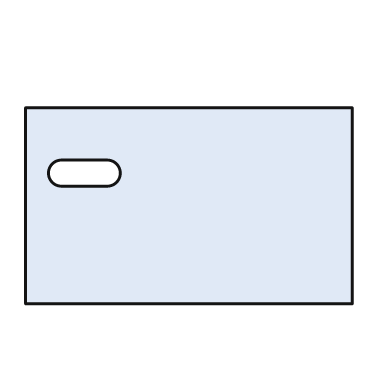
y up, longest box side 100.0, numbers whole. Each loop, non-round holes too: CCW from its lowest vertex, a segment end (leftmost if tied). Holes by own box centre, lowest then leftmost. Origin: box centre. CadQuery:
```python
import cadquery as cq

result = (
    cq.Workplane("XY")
    .moveTo(-50.0, -30.0)
    .lineTo(50.0, -30.0)
    .lineTo(50.0, 30.0)
    .lineTo(-50.0, 30.0)
    .close()
    .moveTo(-39.0, 6.0)
    .lineTo(-25.0, 6.0)
    .threePointArc((-21.0, 10.0), (-25.0, 14.0))
    .lineTo(-39.0, 14.0)
    .threePointArc((-43.0, 10.0), (-39.0, 6.0))
    .close()
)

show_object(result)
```